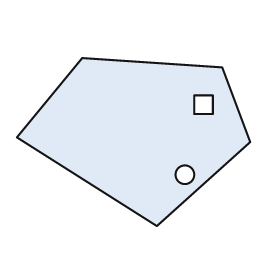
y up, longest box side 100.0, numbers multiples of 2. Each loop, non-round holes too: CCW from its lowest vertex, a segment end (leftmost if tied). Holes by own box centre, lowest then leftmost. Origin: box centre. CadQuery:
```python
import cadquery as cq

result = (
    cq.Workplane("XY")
    .moveTo(10.0, -36.0)
    .lineTo(50.0, 0.0)
    .lineTo(38.0, 32.0)
    .lineTo(-22.0, 36.0)
    .lineTo(-50.0, 2.0)
    .close()
    .moveTo(22.0, -14.0)
    .circle(4.0)
    .moveTo(26.0, 12.0)
    .lineTo(34.0, 12.0)
    .lineTo(34.0, 20.0)
    .lineTo(26.0, 20.0)
    .close()
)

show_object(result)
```